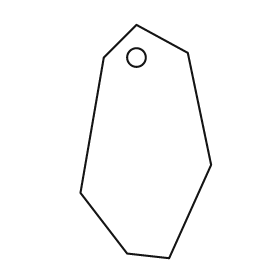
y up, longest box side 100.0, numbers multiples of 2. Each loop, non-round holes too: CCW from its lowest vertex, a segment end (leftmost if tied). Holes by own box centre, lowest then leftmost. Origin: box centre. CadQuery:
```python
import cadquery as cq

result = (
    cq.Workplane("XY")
    .moveTo(10.0, -50.0)
    .lineTo(28.0, -10.0)
    .lineTo(18.0, 38.0)
    .lineTo(-4.0, 50.0)
    .lineTo(-18.0, 36.0)
    .lineTo(-28.0, -22.0)
    .lineTo(-8.0, -48.0)
    .close()
    .moveTo(-4.0, 36.0)
    .circle(4.0)
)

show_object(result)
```